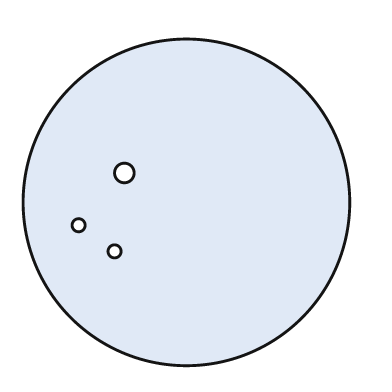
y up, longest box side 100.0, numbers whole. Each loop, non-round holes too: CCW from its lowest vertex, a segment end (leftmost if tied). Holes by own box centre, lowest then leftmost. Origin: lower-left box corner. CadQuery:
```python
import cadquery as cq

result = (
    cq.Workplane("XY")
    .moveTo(50.0, 50.0)
    .circle(50.0)
    .moveTo(28.0, 35.0)
    .circle(2.0)
    .moveTo(17.0, 43.0)
    .circle(2.0)
    .moveTo(31.0, 59.0)
    .circle(3.0)
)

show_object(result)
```